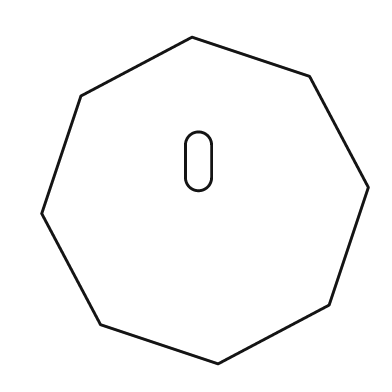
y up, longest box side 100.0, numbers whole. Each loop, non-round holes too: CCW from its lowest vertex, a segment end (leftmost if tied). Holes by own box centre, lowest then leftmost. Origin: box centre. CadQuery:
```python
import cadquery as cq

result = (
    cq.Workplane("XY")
    .moveTo(4.0, -50.0)
    .lineTo(38.0, -32.0)
    .lineTo(50.0, 4.0)
    .lineTo(32.0, 38.0)
    .lineTo(-4.0, 50.0)
    .lineTo(-38.0, 32.0)
    .lineTo(-50.0, -4.0)
    .lineTo(-32.0, -38.0)
    .close()
    .moveTo(-6.0, 7.0)
    .threePointArc((-2.0, 3.0), (2.0, 7.0))
    .lineTo(2.0, 17.0)
    .threePointArc((-2.0, 21.0), (-6.0, 17.0))
    .close()
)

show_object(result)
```